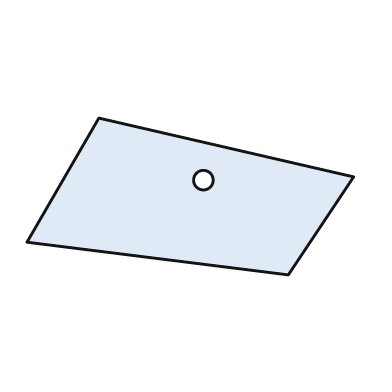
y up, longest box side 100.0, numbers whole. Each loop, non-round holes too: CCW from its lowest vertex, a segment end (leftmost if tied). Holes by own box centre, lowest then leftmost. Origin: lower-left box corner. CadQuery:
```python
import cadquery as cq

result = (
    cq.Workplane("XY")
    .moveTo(80.0, 0.0)
    .lineTo(100.0, 30.0)
    .lineTo(22.0, 48.0)
    .lineTo(0.0, 10.0)
    .close()
    .moveTo(54.0, 29.0)
    .circle(3.0)
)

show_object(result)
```